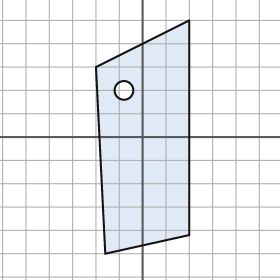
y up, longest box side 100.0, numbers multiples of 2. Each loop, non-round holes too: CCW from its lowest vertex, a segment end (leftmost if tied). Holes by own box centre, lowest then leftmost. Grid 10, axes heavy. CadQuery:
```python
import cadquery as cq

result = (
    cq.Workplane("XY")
    .moveTo(-16.0, -50.0)
    .lineTo(20.0, -42.0)
    .lineTo(20.0, 50.0)
    .lineTo(-20.0, 30.0)
    .close()
    .moveTo(-8.0, 20.0)
    .circle(4.0)
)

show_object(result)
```